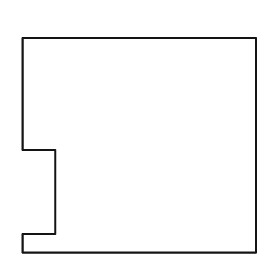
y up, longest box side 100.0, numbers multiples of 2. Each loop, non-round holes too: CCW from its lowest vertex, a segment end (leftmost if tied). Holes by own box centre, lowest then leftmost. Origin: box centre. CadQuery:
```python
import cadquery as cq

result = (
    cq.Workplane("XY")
    .moveTo(-50.0, -46.0)
    .lineTo(50.0, -46.0)
    .lineTo(50.0, 46.0)
    .lineTo(-50.0, 46.0)
    .lineTo(-50.0, -2.0)
    .lineTo(-36.0, -2.0)
    .lineTo(-36.0, -38.0)
    .lineTo(-50.0, -38.0)
    .close()
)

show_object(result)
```